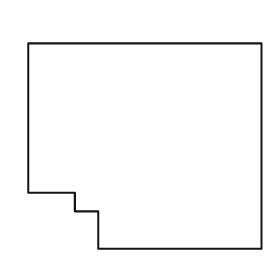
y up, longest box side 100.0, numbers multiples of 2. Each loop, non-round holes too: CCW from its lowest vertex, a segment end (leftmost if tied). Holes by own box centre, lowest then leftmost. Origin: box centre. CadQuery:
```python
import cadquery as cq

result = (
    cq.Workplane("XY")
    .moveTo(-20.0, -44.0)
    .lineTo(50.0, -44.0)
    .lineTo(50.0, 44.0)
    .lineTo(-50.0, 44.0)
    .lineTo(-50.0, -20.0)
    .lineTo(-30.0, -20.0)
    .lineTo(-30.0, -28.0)
    .lineTo(-20.0, -28.0)
    .close()
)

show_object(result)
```